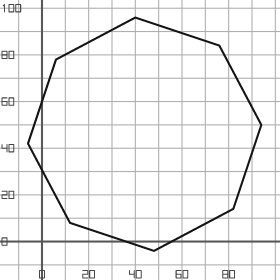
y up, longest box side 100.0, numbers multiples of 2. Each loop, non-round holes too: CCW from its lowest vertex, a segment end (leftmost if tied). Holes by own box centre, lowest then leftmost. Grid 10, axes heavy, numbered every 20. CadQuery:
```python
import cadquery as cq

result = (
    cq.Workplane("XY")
    .moveTo(48.0, -4.0)
    .lineTo(82.0, 14.0)
    .lineTo(94.0, 50.0)
    .lineTo(76.0, 84.0)
    .lineTo(40.0, 96.0)
    .lineTo(6.0, 78.0)
    .lineTo(-6.0, 42.0)
    .lineTo(12.0, 8.0)
    .close()
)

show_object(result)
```